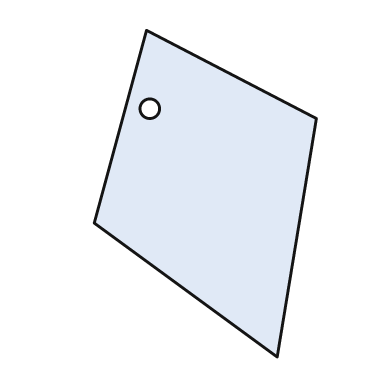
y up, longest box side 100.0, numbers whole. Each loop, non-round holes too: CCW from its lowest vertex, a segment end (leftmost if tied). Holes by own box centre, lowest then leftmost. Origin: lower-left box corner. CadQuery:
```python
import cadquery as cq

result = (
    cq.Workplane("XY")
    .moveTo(56.0, 0.0)
    .lineTo(68.0, 73.0)
    .lineTo(16.0, 100.0)
    .lineTo(0.0, 41.0)
    .close()
    .moveTo(17.0, 76.0)
    .circle(3.0)
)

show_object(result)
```